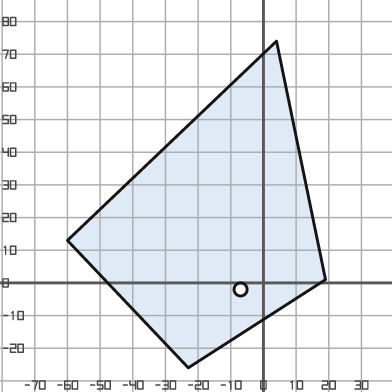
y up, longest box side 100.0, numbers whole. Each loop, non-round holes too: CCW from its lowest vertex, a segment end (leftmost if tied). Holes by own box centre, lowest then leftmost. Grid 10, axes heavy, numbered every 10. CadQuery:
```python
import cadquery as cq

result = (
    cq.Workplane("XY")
    .moveTo(-23.0, -26.0)
    .lineTo(19.0, 1.0)
    .lineTo(4.0, 74.0)
    .lineTo(-60.0, 13.0)
    .close()
    .moveTo(-7.0, -2.0)
    .circle(2.0)
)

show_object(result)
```